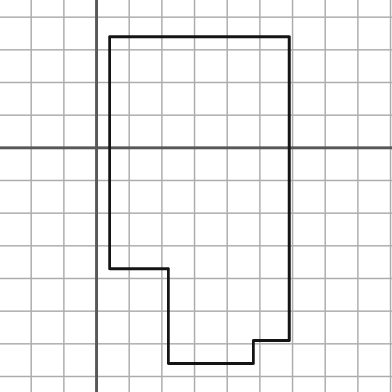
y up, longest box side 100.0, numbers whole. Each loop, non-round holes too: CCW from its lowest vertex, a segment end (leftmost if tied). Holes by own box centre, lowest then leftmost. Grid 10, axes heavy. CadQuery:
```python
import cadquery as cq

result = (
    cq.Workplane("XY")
    .moveTo(22.0, -66.0)
    .lineTo(48.0, -66.0)
    .lineTo(48.0, -59.0)
    .lineTo(59.0, -59.0)
    .lineTo(59.0, 34.0)
    .lineTo(4.0, 34.0)
    .lineTo(4.0, -37.0)
    .lineTo(22.0, -37.0)
    .close()
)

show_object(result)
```